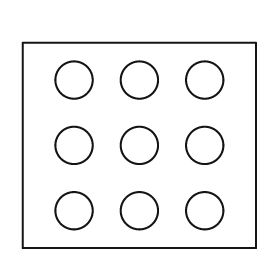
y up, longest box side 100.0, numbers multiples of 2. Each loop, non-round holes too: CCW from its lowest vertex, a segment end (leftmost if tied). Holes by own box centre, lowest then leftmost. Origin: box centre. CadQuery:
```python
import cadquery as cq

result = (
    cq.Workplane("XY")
    .moveTo(-50.0, -44.0)
    .lineTo(50.0, -44.0)
    .lineTo(50.0, 44.0)
    .lineTo(-50.0, 44.0)
    .close()
    .moveTo(-28.0, -28.0)
    .circle(8.0)
    .moveTo(0.0, -28.0)
    .circle(8.0)
    .moveTo(28.0, -28.0)
    .circle(8.0)
    .moveTo(-28.0, 0.0)
    .circle(8.0)
    .moveTo(0.0, 0.0)
    .circle(8.0)
    .moveTo(28.0, 0.0)
    .circle(8.0)
    .moveTo(-28.0, 28.0)
    .circle(8.0)
    .moveTo(0.0, 28.0)
    .circle(8.0)
    .moveTo(28.0, 28.0)
    .circle(8.0)
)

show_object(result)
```